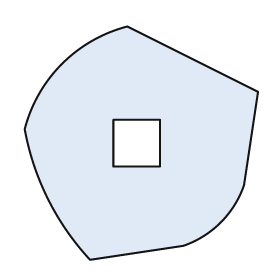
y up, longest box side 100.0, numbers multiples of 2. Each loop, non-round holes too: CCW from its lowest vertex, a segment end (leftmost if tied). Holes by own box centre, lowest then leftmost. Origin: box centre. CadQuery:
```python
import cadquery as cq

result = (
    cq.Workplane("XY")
    .moveTo(-22.0, -50.0)
    .lineTo(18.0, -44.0)
    .threePointArc((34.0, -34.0), (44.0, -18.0))
    .lineTo(50.0, 22.0)
    .lineTo(-6.0, 50.0)
    .threePointArc((-34.0, 34.0), (-50.0, 6.0))
    .threePointArc((-40.0, -24.0), (-22.0, -50.0))
    .close()
    .moveTo(-12.0, -10.0)
    .lineTo(8.0, -10.0)
    .lineTo(8.0, 10.0)
    .lineTo(-12.0, 10.0)
    .close()
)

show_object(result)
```